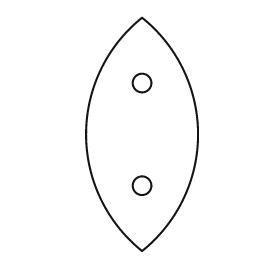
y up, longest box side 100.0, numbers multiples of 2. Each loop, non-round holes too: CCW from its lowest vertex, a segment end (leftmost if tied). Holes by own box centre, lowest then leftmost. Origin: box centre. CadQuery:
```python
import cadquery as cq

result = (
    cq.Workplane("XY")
    .moveTo(0.0, -50.0)
    .threePointArc((24.0, 0.0), (0.0, 50.0))
    .threePointArc((-24.0, 0.0), (0.0, -50.0))
    .close()
    .moveTo(0.0, -22.0)
    .circle(4.0)
    .moveTo(0.0, 22.0)
    .circle(4.0)
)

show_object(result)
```